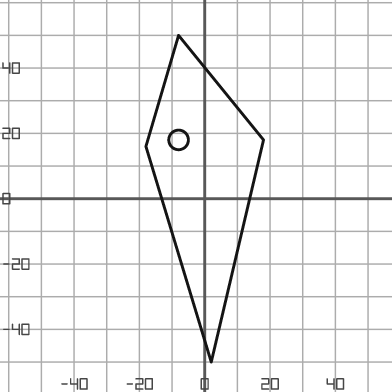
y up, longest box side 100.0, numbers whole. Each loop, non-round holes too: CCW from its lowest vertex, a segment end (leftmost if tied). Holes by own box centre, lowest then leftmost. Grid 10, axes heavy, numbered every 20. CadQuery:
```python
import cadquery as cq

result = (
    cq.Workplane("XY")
    .moveTo(2.0, -50.0)
    .lineTo(18.0, 18.0)
    .lineTo(-8.0, 50.0)
    .lineTo(-18.0, 16.0)
    .close()
    .moveTo(-8.0, 18.0)
    .circle(3.0)
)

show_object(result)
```